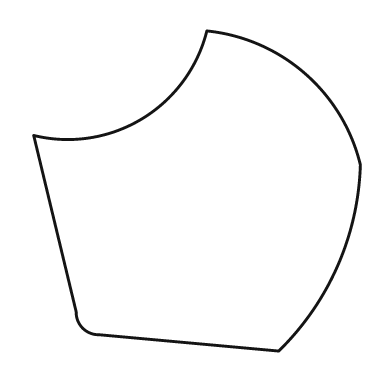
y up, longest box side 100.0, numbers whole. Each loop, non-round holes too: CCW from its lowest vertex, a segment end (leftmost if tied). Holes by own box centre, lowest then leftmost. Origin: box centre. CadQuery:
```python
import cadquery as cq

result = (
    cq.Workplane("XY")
    .moveTo(25.0, -49.0)
    .threePointArc((43.0, -23.0), (50.0, 8.0))
    .threePointArc((33.0, 36.0), (3.0, 49.0))
    .threePointArc((-17.0, 22.0), (-50.0, 17.0))
    .lineTo(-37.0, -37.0)
    .threePointArc((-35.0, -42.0), (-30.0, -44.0))
    .close()
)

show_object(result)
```